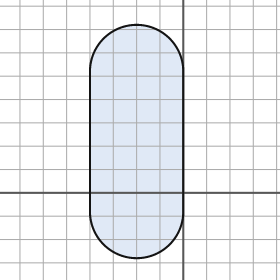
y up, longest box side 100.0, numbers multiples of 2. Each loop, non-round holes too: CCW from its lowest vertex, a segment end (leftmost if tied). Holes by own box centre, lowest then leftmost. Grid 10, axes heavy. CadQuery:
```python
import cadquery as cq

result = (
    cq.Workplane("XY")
    .moveTo(-40.0, -8.0)
    .threePointArc((-20.0, -28.0), (0.0, -8.0))
    .lineTo(0.0, 52.0)
    .threePointArc((-20.0, 72.0), (-40.0, 52.0))
    .close()
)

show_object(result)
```